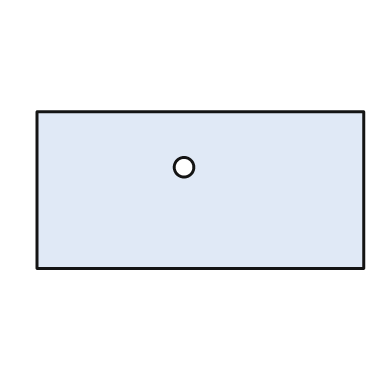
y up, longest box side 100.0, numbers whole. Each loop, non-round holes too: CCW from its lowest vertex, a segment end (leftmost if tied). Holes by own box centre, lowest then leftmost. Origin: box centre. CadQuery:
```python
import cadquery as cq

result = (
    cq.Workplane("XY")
    .moveTo(-50.0, -24.0)
    .lineTo(50.0, -24.0)
    .lineTo(50.0, 24.0)
    .lineTo(-50.0, 24.0)
    .close()
    .moveTo(-5.0, 7.0)
    .circle(3.0)
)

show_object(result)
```